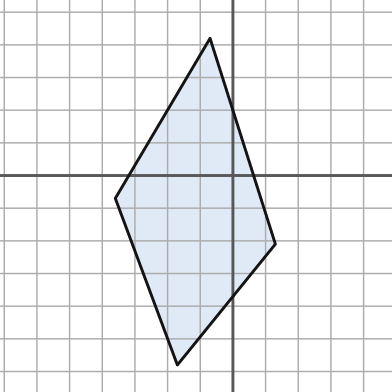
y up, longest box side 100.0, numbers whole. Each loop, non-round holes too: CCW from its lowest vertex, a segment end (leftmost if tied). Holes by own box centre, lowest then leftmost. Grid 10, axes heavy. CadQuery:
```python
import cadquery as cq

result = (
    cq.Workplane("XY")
    .moveTo(-17.0, -58.0)
    .lineTo(13.0, -21.0)
    .lineTo(-7.0, 42.0)
    .lineTo(-36.0, -7.0)
    .close()
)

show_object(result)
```